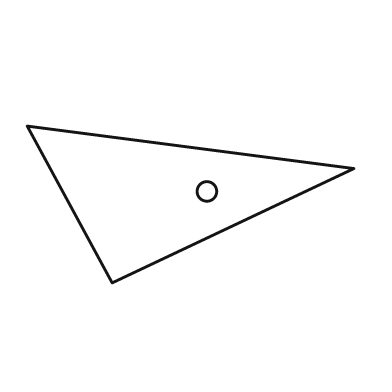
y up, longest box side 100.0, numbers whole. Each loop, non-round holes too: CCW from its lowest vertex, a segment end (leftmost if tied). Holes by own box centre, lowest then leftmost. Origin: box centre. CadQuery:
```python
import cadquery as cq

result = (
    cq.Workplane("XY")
    .moveTo(-24.0, -24.0)
    .lineTo(50.0, 11.0)
    .lineTo(-50.0, 24.0)
    .close()
    .moveTo(5.0, 4.0)
    .circle(3.0)
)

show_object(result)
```